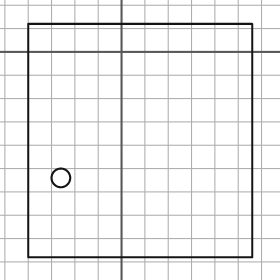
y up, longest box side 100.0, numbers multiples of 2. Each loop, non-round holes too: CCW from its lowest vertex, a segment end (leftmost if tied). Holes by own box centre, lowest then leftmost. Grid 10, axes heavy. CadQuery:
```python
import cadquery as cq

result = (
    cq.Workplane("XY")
    .moveTo(-40.0, -88.0)
    .lineTo(56.0, -88.0)
    .lineTo(56.0, 12.0)
    .lineTo(-40.0, 12.0)
    .close()
    .moveTo(-26.0, -54.0)
    .circle(4.0)
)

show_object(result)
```